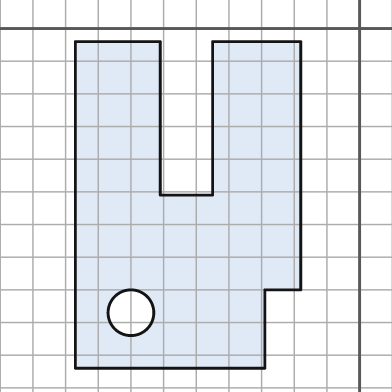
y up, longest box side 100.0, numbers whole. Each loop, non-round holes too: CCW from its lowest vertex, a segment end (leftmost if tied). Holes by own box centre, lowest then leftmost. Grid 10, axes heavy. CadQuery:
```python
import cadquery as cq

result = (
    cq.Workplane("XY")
    .moveTo(-87.0, -104.0)
    .lineTo(-29.0, -104.0)
    .lineTo(-29.0, -80.0)
    .lineTo(-18.0, -80.0)
    .lineTo(-18.0, -4.0)
    .lineTo(-45.0, -4.0)
    .lineTo(-45.0, -51.0)
    .lineTo(-61.0, -51.0)
    .lineTo(-61.0, -4.0)
    .lineTo(-87.0, -4.0)
    .close()
    .moveTo(-70.0, -87.0)
    .circle(7.0)
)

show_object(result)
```